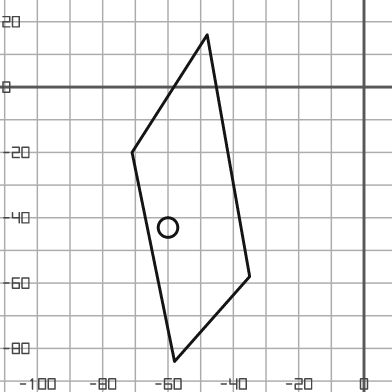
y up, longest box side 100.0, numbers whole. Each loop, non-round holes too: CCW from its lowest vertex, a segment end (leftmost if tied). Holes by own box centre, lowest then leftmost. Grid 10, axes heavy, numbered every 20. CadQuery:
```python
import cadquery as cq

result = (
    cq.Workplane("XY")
    .moveTo(-58.0, -84.0)
    .lineTo(-35.0, -58.0)
    .lineTo(-48.0, 16.0)
    .lineTo(-71.0, -20.0)
    .close()
    .moveTo(-60.0, -43.0)
    .circle(3.0)
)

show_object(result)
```